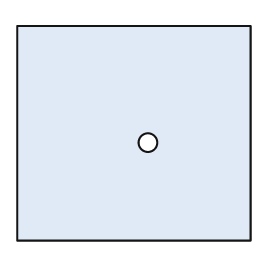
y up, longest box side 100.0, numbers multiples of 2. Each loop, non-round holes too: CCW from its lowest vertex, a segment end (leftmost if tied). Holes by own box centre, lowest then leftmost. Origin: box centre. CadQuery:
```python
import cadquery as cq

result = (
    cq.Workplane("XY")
    .moveTo(-50.0, -46.0)
    .lineTo(50.0, -46.0)
    .lineTo(50.0, 46.0)
    .lineTo(-50.0, 46.0)
    .close()
    .moveTo(6.0, -4.0)
    .circle(4.0)
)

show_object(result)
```